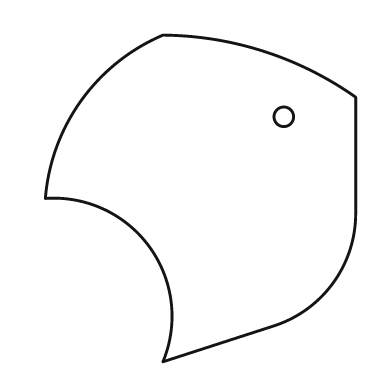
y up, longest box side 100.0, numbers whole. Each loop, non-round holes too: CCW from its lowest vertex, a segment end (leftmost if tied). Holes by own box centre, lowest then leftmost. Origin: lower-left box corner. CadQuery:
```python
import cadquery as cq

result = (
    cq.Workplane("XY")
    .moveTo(36.0, 0.0)
    .lineTo(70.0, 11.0)
    .threePointArc((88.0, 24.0), (95.0, 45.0))
    .lineTo(95.0, 81.0)
    .threePointArc((67.0, 95.0), (36.0, 100.0))
    .threePointArc((11.0, 80.0), (0.0, 50.0))
    .threePointArc((32.0, 35.0), (36.0, 0.0))
    .close()
    .moveTo(73.0, 75.0)
    .circle(3.0)
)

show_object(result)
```